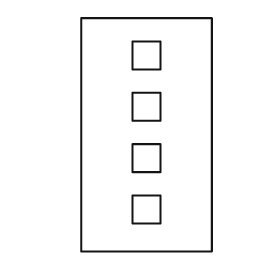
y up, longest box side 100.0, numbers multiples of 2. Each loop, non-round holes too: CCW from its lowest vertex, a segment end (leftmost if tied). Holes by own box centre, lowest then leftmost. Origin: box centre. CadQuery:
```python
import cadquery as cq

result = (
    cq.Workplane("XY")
    .moveTo(-28.0, -50.0)
    .lineTo(28.0, -50.0)
    .lineTo(28.0, 50.0)
    .lineTo(-28.0, 50.0)
    .close()
    .moveTo(-6.0, -38.0)
    .lineTo(6.0, -38.0)
    .lineTo(6.0, -26.0)
    .lineTo(-6.0, -26.0)
    .close()
    .moveTo(-6.0, -16.0)
    .lineTo(6.0, -16.0)
    .lineTo(6.0, -4.0)
    .lineTo(-6.0, -4.0)
    .close()
    .moveTo(-6.0, 6.0)
    .lineTo(6.0, 6.0)
    .lineTo(6.0, 18.0)
    .lineTo(-6.0, 18.0)
    .close()
    .moveTo(-6.0, 28.0)
    .lineTo(6.0, 28.0)
    .lineTo(6.0, 40.0)
    .lineTo(-6.0, 40.0)
    .close()
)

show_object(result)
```